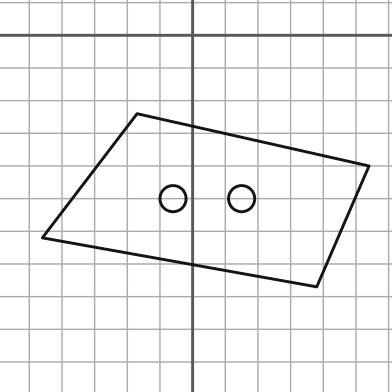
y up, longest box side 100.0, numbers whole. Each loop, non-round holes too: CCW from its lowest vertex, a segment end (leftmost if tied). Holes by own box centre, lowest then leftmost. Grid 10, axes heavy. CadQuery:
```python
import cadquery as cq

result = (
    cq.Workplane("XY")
    .moveTo(38.0, -77.0)
    .lineTo(54.0, -40.0)
    .lineTo(-17.0, -24.0)
    .lineTo(-46.0, -62.0)
    .close()
    .moveTo(-6.0, -50.0)
    .circle(4.0)
    .moveTo(15.0, -50.0)
    .circle(4.0)
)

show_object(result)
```